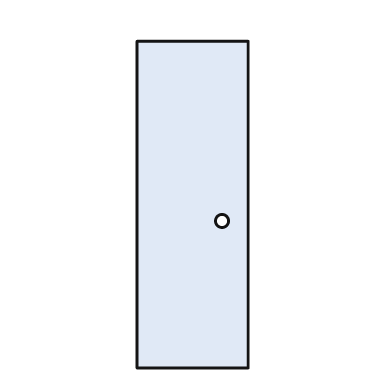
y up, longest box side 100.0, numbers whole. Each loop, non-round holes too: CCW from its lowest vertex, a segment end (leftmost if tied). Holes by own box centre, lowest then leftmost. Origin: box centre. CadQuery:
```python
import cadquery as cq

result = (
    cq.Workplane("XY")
    .moveTo(-17.0, -50.0)
    .lineTo(17.0, -50.0)
    .lineTo(17.0, 50.0)
    .lineTo(-17.0, 50.0)
    .close()
    .moveTo(9.0, -5.0)
    .circle(2.0)
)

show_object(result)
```